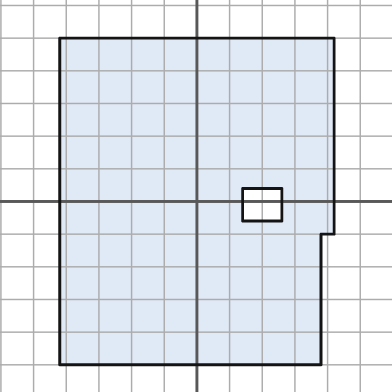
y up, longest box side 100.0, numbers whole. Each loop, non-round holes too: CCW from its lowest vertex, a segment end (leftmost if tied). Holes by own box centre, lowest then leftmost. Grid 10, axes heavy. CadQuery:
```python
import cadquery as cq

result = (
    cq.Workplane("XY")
    .moveTo(-42.0, -50.0)
    .lineTo(38.0, -50.0)
    .lineTo(38.0, -10.0)
    .lineTo(42.0, -10.0)
    .lineTo(42.0, 50.0)
    .lineTo(-42.0, 50.0)
    .close()
    .moveTo(14.0, -6.0)
    .lineTo(26.0, -6.0)
    .lineTo(26.0, 4.0)
    .lineTo(14.0, 4.0)
    .close()
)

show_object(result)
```